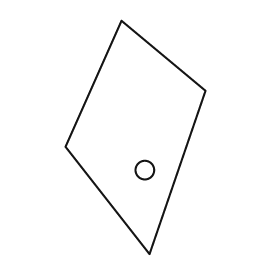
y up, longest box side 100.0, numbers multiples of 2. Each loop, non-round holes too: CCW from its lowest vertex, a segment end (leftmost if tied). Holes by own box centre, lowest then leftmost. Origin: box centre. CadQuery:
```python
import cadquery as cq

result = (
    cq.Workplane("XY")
    .moveTo(6.0, -50.0)
    .lineTo(30.0, 20.0)
    .lineTo(-6.0, 50.0)
    .lineTo(-30.0, -4.0)
    .close()
    .moveTo(4.0, -14.0)
    .circle(4.0)
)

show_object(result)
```